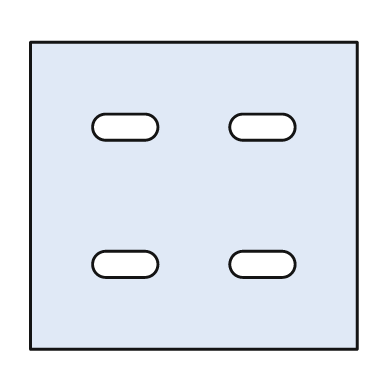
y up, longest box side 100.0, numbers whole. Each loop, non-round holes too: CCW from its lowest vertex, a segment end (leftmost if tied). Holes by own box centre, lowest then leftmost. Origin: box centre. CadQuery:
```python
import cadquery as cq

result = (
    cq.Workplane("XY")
    .moveTo(-50.0, -47.0)
    .lineTo(50.0, -47.0)
    .lineTo(50.0, 47.0)
    .lineTo(-50.0, 47.0)
    .close()
    .moveTo(-27.0, -25.0)
    .lineTo(-15.0, -25.0)
    .threePointArc((-11.0, -21.0), (-15.0, -17.0))
    .lineTo(-27.0, -17.0)
    .threePointArc((-31.0, -21.0), (-27.0, -25.0))
    .close()
    .moveTo(15.0, -25.0)
    .lineTo(27.0, -25.0)
    .threePointArc((31.0, -21.0), (27.0, -17.0))
    .lineTo(15.0, -17.0)
    .threePointArc((11.0, -21.0), (15.0, -25.0))
    .close()
    .moveTo(-27.0, 17.0)
    .lineTo(-15.0, 17.0)
    .threePointArc((-11.0, 21.0), (-15.0, 25.0))
    .lineTo(-27.0, 25.0)
    .threePointArc((-31.0, 21.0), (-27.0, 17.0))
    .close()
    .moveTo(15.0, 17.0)
    .lineTo(27.0, 17.0)
    .threePointArc((31.0, 21.0), (27.0, 25.0))
    .lineTo(15.0, 25.0)
    .threePointArc((11.0, 21.0), (15.0, 17.0))
    .close()
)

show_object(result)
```